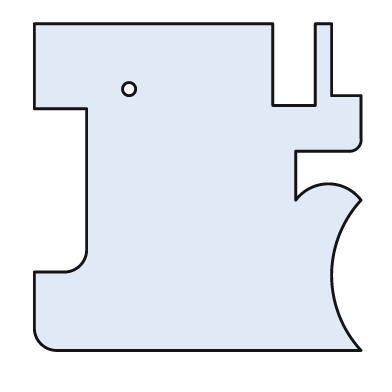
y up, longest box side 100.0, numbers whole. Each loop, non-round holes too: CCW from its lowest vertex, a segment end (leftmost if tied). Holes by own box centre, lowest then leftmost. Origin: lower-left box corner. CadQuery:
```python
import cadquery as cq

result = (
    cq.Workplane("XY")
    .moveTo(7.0, 0.0)
    .lineTo(100.0, 0.0)
    .threePointArc((91.0, 23.0), (100.0, 46.0))
    .threePointArc((90.0, 51.0), (80.0, 46.0))
    .lineTo(80.0, 61.0)
    .lineTo(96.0, 61.0)
    .threePointArc((99.0, 62.0), (100.0, 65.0))
    .lineTo(100.0, 78.0)
    .lineTo(91.0, 78.0)
    .lineTo(91.0, 100.0)
    .lineTo(86.0, 100.0)
    .lineTo(86.0, 75.0)
    .lineTo(73.0, 75.0)
    .lineTo(73.0, 100.0)
    .lineTo(0.0, 100.0)
    .lineTo(0.0, 74.0)
    .lineTo(16.0, 74.0)
    .lineTo(16.0, 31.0)
    .threePointArc((14.0, 26.0), (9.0, 24.0))
    .lineTo(0.0, 24.0)
    .lineTo(0.0, 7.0)
    .threePointArc((2.0, 2.0), (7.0, 0.0))
    .close()
    .moveTo(29.0, 80.0)
    .circle(2.0)
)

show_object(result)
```